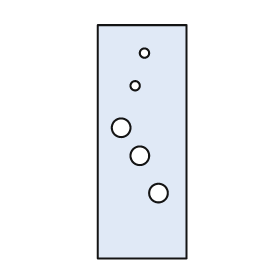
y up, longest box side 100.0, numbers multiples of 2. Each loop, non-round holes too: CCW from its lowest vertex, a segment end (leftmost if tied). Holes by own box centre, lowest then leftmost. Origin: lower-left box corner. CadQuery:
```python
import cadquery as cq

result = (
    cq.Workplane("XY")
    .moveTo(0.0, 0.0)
    .lineTo(38.0, 0.0)
    .lineTo(38.0, 100.0)
    .lineTo(0.0, 100.0)
    .close()
    .moveTo(26.0, 28.0)
    .circle(4.0)
    .moveTo(18.0, 44.0)
    .circle(4.0)
    .moveTo(10.0, 56.0)
    .circle(4.0)
    .moveTo(16.0, 74.0)
    .circle(2.0)
    .moveTo(20.0, 88.0)
    .circle(2.0)
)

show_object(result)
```